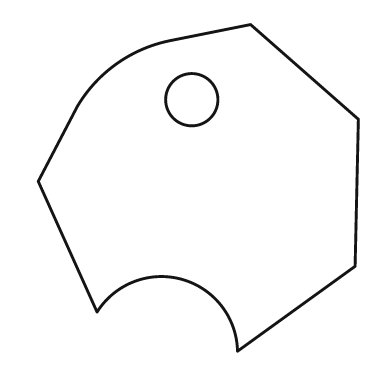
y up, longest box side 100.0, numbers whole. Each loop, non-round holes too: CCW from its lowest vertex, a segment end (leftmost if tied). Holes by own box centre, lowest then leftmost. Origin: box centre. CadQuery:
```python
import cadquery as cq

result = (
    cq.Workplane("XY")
    .moveTo(12.0, -50.0)
    .lineTo(48.0, -24.0)
    .lineTo(49.0, 21.0)
    .lineTo(16.0, 50.0)
    .lineTo(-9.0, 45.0)
    .threePointArc((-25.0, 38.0), (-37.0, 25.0))
    .lineTo(-49.0, 2.0)
    .lineTo(-31.0, -38.0)
    .threePointArc((-5.0, -28.0), (12.0, -50.0))
    .close()
    .moveTo(-2.0, 27.0)
    .circle(8.0)
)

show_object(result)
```